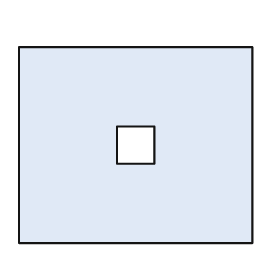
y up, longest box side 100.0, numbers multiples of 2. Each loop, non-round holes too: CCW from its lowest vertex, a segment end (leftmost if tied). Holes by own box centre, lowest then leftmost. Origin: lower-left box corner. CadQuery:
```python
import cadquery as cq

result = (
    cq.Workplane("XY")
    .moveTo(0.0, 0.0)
    .lineTo(100.0, 0.0)
    .lineTo(100.0, 84.0)
    .lineTo(0.0, 84.0)
    .close()
    .moveTo(42.0, 34.0)
    .lineTo(58.0, 34.0)
    .lineTo(58.0, 50.0)
    .lineTo(42.0, 50.0)
    .close()
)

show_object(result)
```